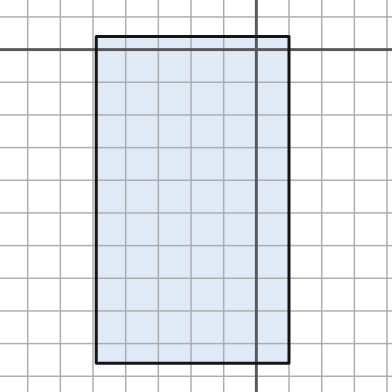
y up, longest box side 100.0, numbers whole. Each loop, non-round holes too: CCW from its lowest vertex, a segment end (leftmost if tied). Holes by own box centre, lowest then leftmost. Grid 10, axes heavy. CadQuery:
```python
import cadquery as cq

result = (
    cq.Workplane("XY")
    .moveTo(-49.0, -96.0)
    .lineTo(10.0, -96.0)
    .lineTo(10.0, 4.0)
    .lineTo(-49.0, 4.0)
    .close()
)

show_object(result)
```